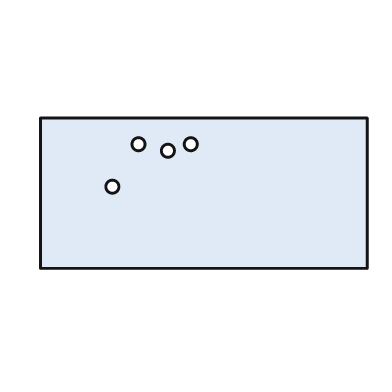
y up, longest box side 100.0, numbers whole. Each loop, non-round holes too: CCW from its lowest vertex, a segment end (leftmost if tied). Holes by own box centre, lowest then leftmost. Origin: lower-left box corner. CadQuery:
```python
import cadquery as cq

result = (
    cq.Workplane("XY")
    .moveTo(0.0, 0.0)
    .lineTo(100.0, 0.0)
    .lineTo(100.0, 46.0)
    .lineTo(0.0, 46.0)
    .close()
    .moveTo(22.0, 25.0)
    .circle(2.0)
    .moveTo(39.0, 36.0)
    .circle(2.0)
    .moveTo(30.0, 38.0)
    .circle(2.0)
    .moveTo(46.0, 38.0)
    .circle(2.0)
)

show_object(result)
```